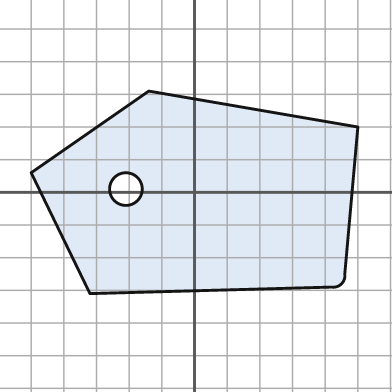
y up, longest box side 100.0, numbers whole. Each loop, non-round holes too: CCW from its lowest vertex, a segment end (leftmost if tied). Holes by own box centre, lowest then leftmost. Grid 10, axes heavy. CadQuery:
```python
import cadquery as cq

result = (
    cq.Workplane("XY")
    .moveTo(-32.0, -31.0)
    .lineTo(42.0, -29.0)
    .threePointArc((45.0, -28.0), (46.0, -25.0))
    .lineTo(50.0, 20.0)
    .lineTo(-14.0, 31.0)
    .lineTo(-50.0, 6.0)
    .close()
    .moveTo(-21.0, 1.0)
    .circle(5.0)
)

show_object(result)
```